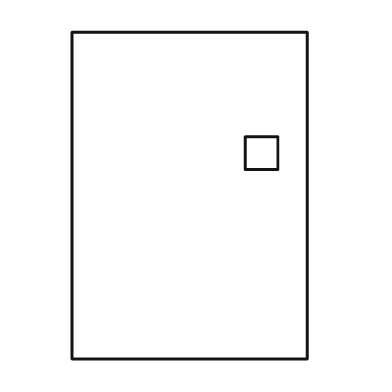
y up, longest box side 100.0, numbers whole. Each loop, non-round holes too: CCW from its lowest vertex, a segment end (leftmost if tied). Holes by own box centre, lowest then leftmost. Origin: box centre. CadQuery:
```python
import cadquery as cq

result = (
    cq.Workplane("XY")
    .moveTo(-36.0, -50.0)
    .lineTo(36.0, -50.0)
    .lineTo(36.0, 50.0)
    .lineTo(-36.0, 50.0)
    .close()
    .moveTo(17.0, 8.0)
    .lineTo(27.0, 8.0)
    .lineTo(27.0, 18.0)
    .lineTo(17.0, 18.0)
    .close()
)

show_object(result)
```